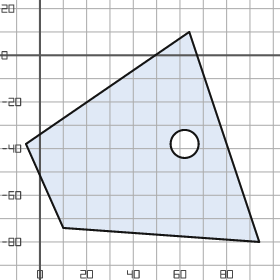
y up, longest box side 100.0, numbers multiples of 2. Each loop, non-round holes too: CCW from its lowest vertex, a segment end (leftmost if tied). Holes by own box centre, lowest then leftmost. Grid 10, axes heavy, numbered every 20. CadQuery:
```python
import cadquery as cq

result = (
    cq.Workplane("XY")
    .moveTo(94.0, -80.0)
    .lineTo(64.0, 10.0)
    .lineTo(-6.0, -38.0)
    .lineTo(10.0, -74.0)
    .close()
    .moveTo(62.0, -38.0)
    .circle(6.0)
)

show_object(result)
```